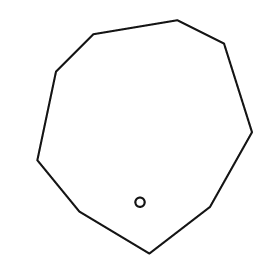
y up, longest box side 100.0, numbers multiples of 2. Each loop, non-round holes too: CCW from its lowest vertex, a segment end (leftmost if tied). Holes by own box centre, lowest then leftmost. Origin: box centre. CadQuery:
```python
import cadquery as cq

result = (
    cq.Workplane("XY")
    .moveTo(2.0, -50.0)
    .lineTo(28.0, -30.0)
    .lineTo(46.0, 2.0)
    .lineTo(34.0, 40.0)
    .lineTo(14.0, 50.0)
    .lineTo(-22.0, 44.0)
    .lineTo(-38.0, 28.0)
    .lineTo(-46.0, -10.0)
    .lineTo(-28.0, -32.0)
    .close()
    .moveTo(-2.0, -28.0)
    .circle(2.0)
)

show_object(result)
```